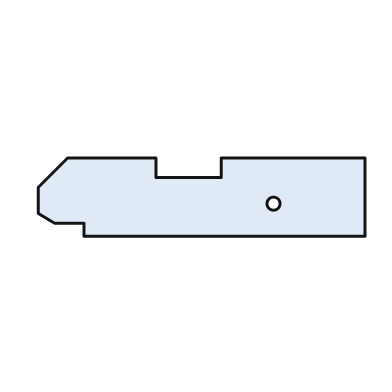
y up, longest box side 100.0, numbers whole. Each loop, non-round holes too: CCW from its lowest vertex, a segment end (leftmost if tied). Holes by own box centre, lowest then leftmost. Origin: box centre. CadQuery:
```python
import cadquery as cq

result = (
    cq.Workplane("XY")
    .moveTo(-36.0, -12.0)
    .lineTo(50.0, -12.0)
    .lineTo(50.0, 12.0)
    .lineTo(6.0, 12.0)
    .lineTo(6.0, 6.0)
    .lineTo(-14.0, 6.0)
    .lineTo(-14.0, 12.0)
    .lineTo(-41.0, 12.0)
    .lineTo(-50.0, 3.0)
    .lineTo(-50.0, -5.0)
    .lineTo(-45.0, -8.0)
    .lineTo(-36.0, -8.0)
    .close()
    .moveTo(22.0, -2.0)
    .circle(2.0)
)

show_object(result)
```